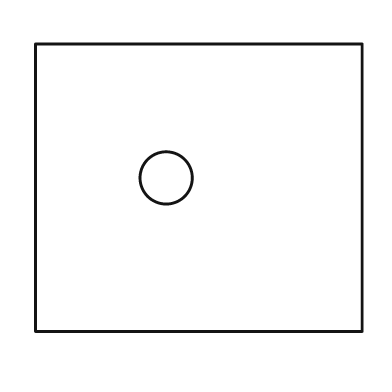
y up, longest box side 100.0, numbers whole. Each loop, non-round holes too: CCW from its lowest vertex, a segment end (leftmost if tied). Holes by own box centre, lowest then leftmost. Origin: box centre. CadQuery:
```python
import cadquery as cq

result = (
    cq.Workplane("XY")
    .moveTo(-50.0, -44.0)
    .lineTo(50.0, -44.0)
    .lineTo(50.0, 44.0)
    .lineTo(-50.0, 44.0)
    .close()
    .moveTo(-10.0, 3.0)
    .circle(8.0)
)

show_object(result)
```